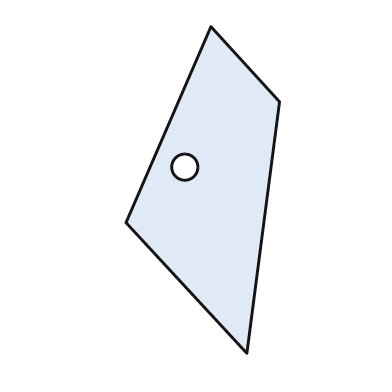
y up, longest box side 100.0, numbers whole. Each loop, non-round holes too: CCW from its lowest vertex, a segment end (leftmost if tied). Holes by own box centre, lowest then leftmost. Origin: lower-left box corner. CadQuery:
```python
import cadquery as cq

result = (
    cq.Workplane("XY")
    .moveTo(37.0, 0.0)
    .lineTo(47.0, 77.0)
    .lineTo(26.0, 100.0)
    .lineTo(0.0, 40.0)
    .close()
    .moveTo(18.0, 57.0)
    .circle(4.0)
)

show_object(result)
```